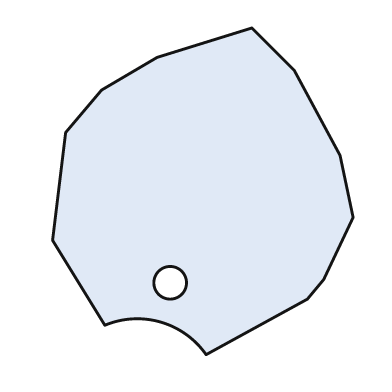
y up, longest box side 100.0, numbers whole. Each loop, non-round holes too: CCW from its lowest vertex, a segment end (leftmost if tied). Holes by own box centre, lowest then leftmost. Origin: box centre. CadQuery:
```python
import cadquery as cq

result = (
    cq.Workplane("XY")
    .moveTo(1.0, -50.0)
    .lineTo(32.0, -33.0)
    .lineTo(37.0, -27.0)
    .lineTo(46.0, -8.0)
    .lineTo(42.0, 11.0)
    .lineTo(28.0, 37.0)
    .lineTo(15.0, 50.0)
    .lineTo(-14.0, 41.0)
    .lineTo(-31.0, 31.0)
    .lineTo(-42.0, 18.0)
    .lineTo(-46.0, -15.0)
    .lineTo(-30.0, -41.0)
    .threePointArc((-13.0, -40.0), (1.0, -50.0))
    .close()
    .moveTo(-10.0, -28.0)
    .circle(5.0)
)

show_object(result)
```